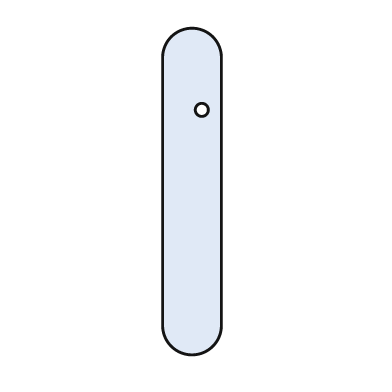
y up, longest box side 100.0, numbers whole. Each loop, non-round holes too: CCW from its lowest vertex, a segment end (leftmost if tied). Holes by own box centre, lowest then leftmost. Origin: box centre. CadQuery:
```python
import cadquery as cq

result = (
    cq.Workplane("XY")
    .moveTo(-9.0, -41.0)
    .threePointArc((0.0, -50.0), (9.0, -41.0))
    .lineTo(9.0, 41.0)
    .threePointArc((0.0, 50.0), (-9.0, 41.0))
    .close()
    .moveTo(3.0, 25.0)
    .circle(2.0)
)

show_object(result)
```